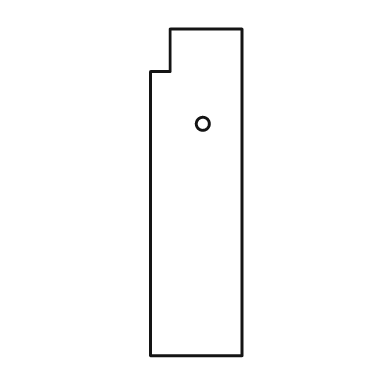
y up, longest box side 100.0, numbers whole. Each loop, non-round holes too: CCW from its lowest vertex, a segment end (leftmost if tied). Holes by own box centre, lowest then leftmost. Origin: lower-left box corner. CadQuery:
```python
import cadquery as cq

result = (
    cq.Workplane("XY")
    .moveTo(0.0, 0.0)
    .lineTo(28.0, 0.0)
    .lineTo(28.0, 100.0)
    .lineTo(6.0, 100.0)
    .lineTo(6.0, 87.0)
    .lineTo(0.0, 87.0)
    .close()
    .moveTo(16.0, 71.0)
    .circle(2.0)
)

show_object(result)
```